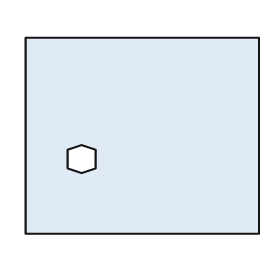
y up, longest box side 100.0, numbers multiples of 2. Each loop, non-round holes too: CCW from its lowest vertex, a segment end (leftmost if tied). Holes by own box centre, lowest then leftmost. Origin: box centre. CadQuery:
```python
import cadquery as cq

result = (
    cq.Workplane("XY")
    .moveTo(-50.0, -42.0)
    .lineTo(50.0, -42.0)
    .lineTo(50.0, 42.0)
    .lineTo(-50.0, 42.0)
    .close()
    .moveTo(-26.0, -16.0)
    .lineTo(-20.0, -14.0)
    .lineTo(-20.0, -6.0)
    .lineTo(-26.0, -4.0)
    .lineTo(-32.0, -6.0)
    .lineTo(-32.0, -14.0)
    .close()
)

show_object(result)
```